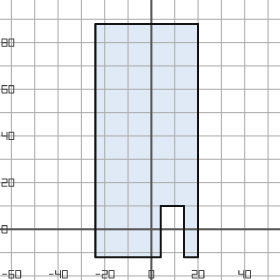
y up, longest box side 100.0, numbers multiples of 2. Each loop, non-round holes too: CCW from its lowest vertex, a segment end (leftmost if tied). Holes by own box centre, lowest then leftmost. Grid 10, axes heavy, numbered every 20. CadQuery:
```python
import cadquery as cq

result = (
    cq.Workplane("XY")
    .moveTo(-24.0, -12.0)
    .lineTo(4.0, -12.0)
    .lineTo(4.0, 10.0)
    .lineTo(14.0, 10.0)
    .lineTo(14.0, -12.0)
    .lineTo(20.0, -12.0)
    .lineTo(20.0, 88.0)
    .lineTo(-24.0, 88.0)
    .close()
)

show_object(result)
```